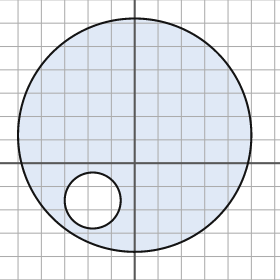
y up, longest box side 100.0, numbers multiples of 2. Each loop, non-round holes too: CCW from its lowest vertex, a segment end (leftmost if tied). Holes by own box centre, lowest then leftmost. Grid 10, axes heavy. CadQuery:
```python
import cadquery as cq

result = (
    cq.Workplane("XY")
    .moveTo(0.0, 12.0)
    .circle(50.0)
    .moveTo(-18.0, -16.0)
    .circle(12.0)
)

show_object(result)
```